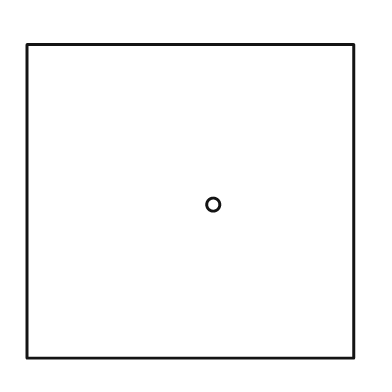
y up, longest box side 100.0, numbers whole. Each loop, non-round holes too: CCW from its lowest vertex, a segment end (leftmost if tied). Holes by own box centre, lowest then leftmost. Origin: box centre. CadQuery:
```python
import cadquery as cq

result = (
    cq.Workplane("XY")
    .moveTo(-50.0, -48.0)
    .lineTo(50.0, -48.0)
    .lineTo(50.0, 48.0)
    .lineTo(-50.0, 48.0)
    .close()
    .moveTo(7.0, -1.0)
    .circle(2.0)
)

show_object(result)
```